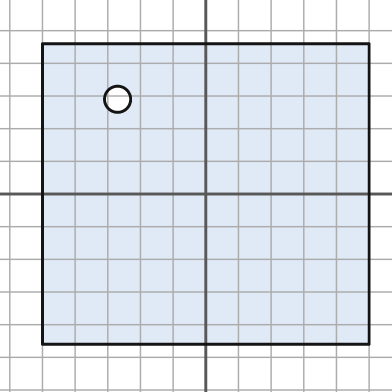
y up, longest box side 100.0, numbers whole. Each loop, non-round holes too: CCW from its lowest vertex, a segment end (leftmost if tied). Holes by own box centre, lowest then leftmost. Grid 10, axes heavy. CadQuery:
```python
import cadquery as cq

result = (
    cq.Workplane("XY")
    .moveTo(-50.0, -46.0)
    .lineTo(50.0, -46.0)
    .lineTo(50.0, 46.0)
    .lineTo(-50.0, 46.0)
    .close()
    .moveTo(-27.0, 29.0)
    .circle(4.0)
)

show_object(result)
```